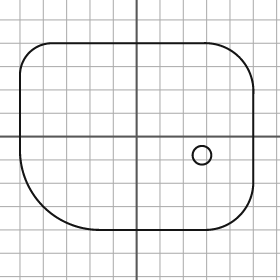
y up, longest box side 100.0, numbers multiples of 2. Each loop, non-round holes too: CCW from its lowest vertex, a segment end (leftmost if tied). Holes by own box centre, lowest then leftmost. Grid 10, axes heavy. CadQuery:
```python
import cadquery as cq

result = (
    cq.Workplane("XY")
    .moveTo(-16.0, -40.0)
    .lineTo(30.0, -40.0)
    .threePointArc((44.0, -34.0), (50.0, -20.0))
    .lineTo(50.0, 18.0)
    .threePointArc((44.0, 34.0), (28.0, 40.0))
    .lineTo(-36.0, 40.0)
    .threePointArc((-46.0, 36.0), (-50.0, 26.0))
    .lineTo(-50.0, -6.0)
    .threePointArc((-40.0, -30.0), (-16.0, -40.0))
    .close()
    .moveTo(28.0, -8.0)
    .circle(4.0)
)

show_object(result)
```